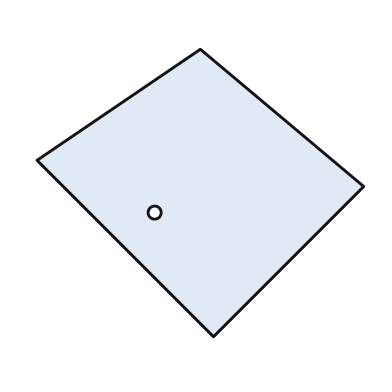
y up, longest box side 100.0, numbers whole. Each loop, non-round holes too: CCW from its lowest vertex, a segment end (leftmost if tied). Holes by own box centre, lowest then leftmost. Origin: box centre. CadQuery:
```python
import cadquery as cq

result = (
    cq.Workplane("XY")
    .moveTo(4.0, -44.0)
    .lineTo(50.0, 2.0)
    .lineTo(0.0, 44.0)
    .lineTo(-50.0, 10.0)
    .close()
    .moveTo(-14.0, -6.0)
    .circle(2.0)
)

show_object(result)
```